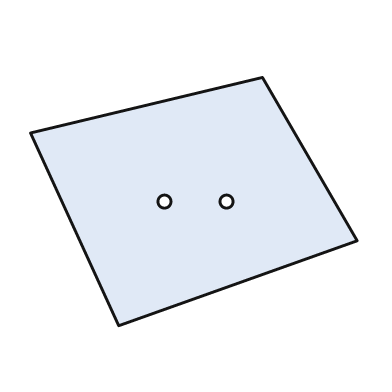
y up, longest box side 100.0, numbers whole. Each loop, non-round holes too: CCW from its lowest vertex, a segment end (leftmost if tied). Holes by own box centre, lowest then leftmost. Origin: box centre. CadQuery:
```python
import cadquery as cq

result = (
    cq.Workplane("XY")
    .moveTo(-23.0, -38.0)
    .lineTo(50.0, -12.0)
    .lineTo(21.0, 38.0)
    .lineTo(-50.0, 21.0)
    .close()
    .moveTo(-9.0, 0.0)
    .circle(2.0)
    .moveTo(10.0, 0.0)
    .circle(2.0)
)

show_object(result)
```